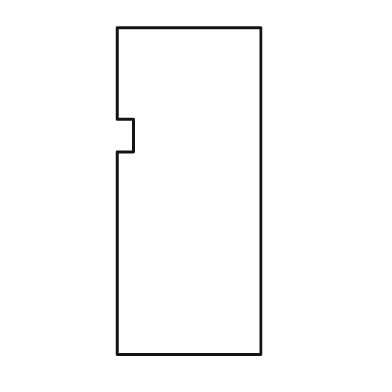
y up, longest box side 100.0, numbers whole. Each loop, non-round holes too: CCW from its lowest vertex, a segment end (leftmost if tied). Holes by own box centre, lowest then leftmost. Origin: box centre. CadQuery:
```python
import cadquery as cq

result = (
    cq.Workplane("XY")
    .moveTo(-22.0, -50.0)
    .lineTo(22.0, -50.0)
    .lineTo(22.0, 50.0)
    .lineTo(-22.0, 50.0)
    .lineTo(-22.0, 22.0)
    .lineTo(-17.0, 22.0)
    .lineTo(-17.0, 12.0)
    .lineTo(-22.0, 12.0)
    .close()
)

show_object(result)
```